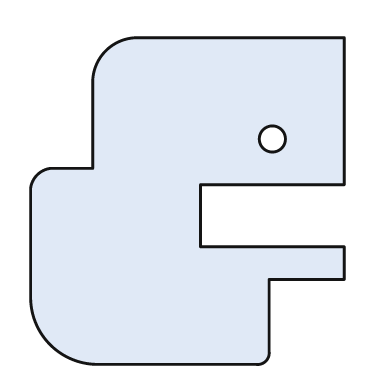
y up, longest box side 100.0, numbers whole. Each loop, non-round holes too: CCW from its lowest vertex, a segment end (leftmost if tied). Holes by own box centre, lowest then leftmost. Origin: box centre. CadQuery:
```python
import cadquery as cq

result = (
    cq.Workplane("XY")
    .moveTo(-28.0, -50.0)
    .lineTo(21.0, -50.0)
    .threePointArc((24.0, -49.0), (25.0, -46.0))
    .lineTo(25.0, -24.0)
    .lineTo(48.0, -24.0)
    .lineTo(48.0, -14.0)
    .lineTo(4.0, -14.0)
    .lineTo(4.0, 5.0)
    .lineTo(48.0, 5.0)
    .lineTo(48.0, 50.0)
    .lineTo(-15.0, 50.0)
    .threePointArc((-25.0, 46.0), (-29.0, 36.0))
    .lineTo(-29.0, 10.0)
    .lineTo(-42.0, 10.0)
    .threePointArc((-46.0, 8.0), (-48.0, 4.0))
    .lineTo(-48.0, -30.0)
    .threePointArc((-42.0, -44.0), (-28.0, -50.0))
    .close()
    .moveTo(26.0, 19.0)
    .circle(4.0)
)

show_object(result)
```